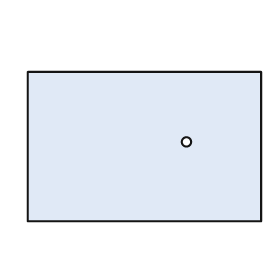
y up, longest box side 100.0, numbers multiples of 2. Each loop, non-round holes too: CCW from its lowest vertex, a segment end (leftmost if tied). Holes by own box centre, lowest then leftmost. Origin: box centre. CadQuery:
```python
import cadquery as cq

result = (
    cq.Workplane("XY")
    .moveTo(-50.0, -32.0)
    .lineTo(50.0, -32.0)
    .lineTo(50.0, 32.0)
    .lineTo(-50.0, 32.0)
    .close()
    .moveTo(18.0, 2.0)
    .circle(2.0)
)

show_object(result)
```